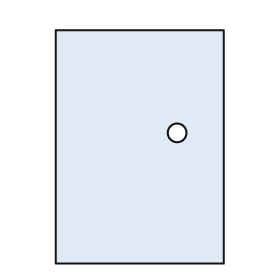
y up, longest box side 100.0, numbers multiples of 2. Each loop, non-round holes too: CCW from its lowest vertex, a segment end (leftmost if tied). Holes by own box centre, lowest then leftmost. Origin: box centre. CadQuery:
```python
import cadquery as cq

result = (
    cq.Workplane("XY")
    .moveTo(-36.0, -50.0)
    .lineTo(36.0, -50.0)
    .lineTo(36.0, 50.0)
    .lineTo(-36.0, 50.0)
    .close()
    .moveTo(16.0, 6.0)
    .circle(4.0)
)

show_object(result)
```